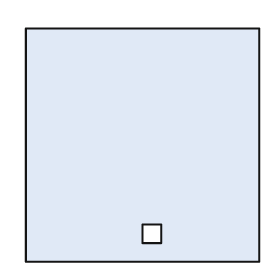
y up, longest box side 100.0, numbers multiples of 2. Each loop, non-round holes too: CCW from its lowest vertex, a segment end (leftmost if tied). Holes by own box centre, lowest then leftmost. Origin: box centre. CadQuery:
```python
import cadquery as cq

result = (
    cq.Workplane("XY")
    .moveTo(-50.0, -50.0)
    .lineTo(50.0, -50.0)
    .lineTo(50.0, 50.0)
    .lineTo(-50.0, 50.0)
    .close()
    .moveTo(0.0, -42.0)
    .lineTo(8.0, -42.0)
    .lineTo(8.0, -34.0)
    .lineTo(0.0, -34.0)
    .close()
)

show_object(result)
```